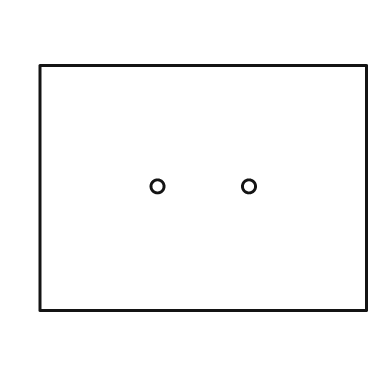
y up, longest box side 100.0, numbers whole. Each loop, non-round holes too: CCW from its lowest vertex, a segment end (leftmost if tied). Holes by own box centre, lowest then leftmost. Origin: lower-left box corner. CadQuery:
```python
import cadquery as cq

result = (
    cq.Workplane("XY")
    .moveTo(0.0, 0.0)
    .lineTo(100.0, 0.0)
    .lineTo(100.0, 75.0)
    .lineTo(0.0, 75.0)
    .close()
    .moveTo(36.0, 38.0)
    .circle(2.0)
    .moveTo(64.0, 38.0)
    .circle(2.0)
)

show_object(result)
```